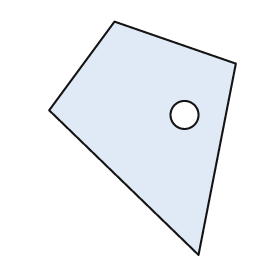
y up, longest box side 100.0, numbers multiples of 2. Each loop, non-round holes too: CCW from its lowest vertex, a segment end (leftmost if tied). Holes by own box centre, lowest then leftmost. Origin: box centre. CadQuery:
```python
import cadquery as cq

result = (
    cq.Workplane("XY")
    .moveTo(24.0, -50.0)
    .lineTo(40.0, 32.0)
    .lineTo(-12.0, 50.0)
    .lineTo(-40.0, 12.0)
    .close()
    .moveTo(18.0, 10.0)
    .circle(6.0)
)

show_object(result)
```